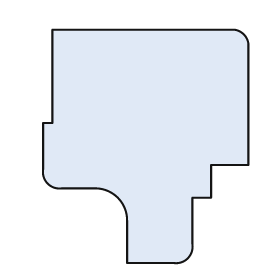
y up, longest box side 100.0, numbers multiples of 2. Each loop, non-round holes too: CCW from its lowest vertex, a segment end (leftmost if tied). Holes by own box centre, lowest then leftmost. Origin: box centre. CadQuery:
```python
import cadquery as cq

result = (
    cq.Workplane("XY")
    .moveTo(-8.0, -50.0)
    .lineTo(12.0, -50.0)
    .threePointArc((18.0, -48.0), (20.0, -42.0))
    .lineTo(20.0, -22.0)
    .lineTo(28.0, -22.0)
    .lineTo(28.0, -8.0)
    .lineTo(44.0, -8.0)
    .lineTo(44.0, 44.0)
    .threePointArc((42.0, 48.0), (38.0, 50.0))
    .lineTo(-40.0, 50.0)
    .lineTo(-40.0, 10.0)
    .lineTo(-44.0, 10.0)
    .lineTo(-44.0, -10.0)
    .threePointArc((-42.0, -16.0), (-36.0, -18.0))
    .lineTo(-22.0, -18.0)
    .threePointArc((-12.0, -22.0), (-8.0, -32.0))
    .close()
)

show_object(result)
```